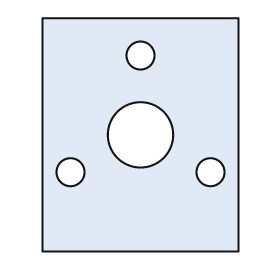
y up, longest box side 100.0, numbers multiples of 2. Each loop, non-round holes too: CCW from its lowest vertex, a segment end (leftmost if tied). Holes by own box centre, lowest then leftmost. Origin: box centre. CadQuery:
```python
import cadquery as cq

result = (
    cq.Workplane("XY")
    .moveTo(-42.0, -50.0)
    .lineTo(42.0, -50.0)
    .lineTo(42.0, 50.0)
    .lineTo(-42.0, 50.0)
    .close()
    .moveTo(-30.0, -16.0)
    .circle(6.0)
    .moveTo(30.0, -16.0)
    .circle(6.0)
    .moveTo(0.0, 0.0)
    .circle(14.0)
    .moveTo(0.0, 34.0)
    .circle(6.0)
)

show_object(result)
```